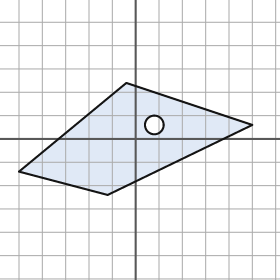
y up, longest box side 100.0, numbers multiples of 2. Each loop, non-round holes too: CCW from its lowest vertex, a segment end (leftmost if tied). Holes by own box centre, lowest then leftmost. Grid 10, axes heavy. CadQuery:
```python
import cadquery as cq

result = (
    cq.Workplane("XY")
    .moveTo(-12.0, -24.0)
    .lineTo(50.0, 6.0)
    .lineTo(-4.0, 24.0)
    .lineTo(-50.0, -14.0)
    .close()
    .moveTo(8.0, 6.0)
    .circle(4.0)
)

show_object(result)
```